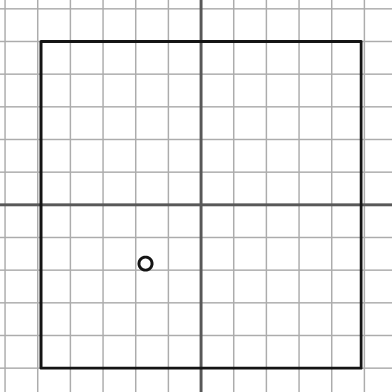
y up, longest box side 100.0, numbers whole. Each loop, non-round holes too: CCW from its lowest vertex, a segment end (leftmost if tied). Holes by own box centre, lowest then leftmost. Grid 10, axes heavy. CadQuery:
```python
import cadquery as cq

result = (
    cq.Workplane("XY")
    .moveTo(-49.0, -50.0)
    .lineTo(49.0, -50.0)
    .lineTo(49.0, 50.0)
    .lineTo(-49.0, 50.0)
    .close()
    .moveTo(-17.0, -18.0)
    .circle(2.0)
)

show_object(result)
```